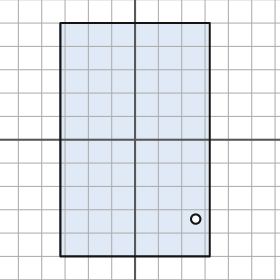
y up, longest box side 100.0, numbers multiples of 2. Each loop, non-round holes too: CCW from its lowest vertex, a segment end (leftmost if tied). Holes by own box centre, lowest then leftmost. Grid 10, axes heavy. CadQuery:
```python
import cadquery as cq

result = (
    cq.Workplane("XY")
    .moveTo(-32.0, -50.0)
    .lineTo(32.0, -50.0)
    .lineTo(32.0, 50.0)
    .lineTo(-32.0, 50.0)
    .close()
    .moveTo(26.0, -34.0)
    .circle(2.0)
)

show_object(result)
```